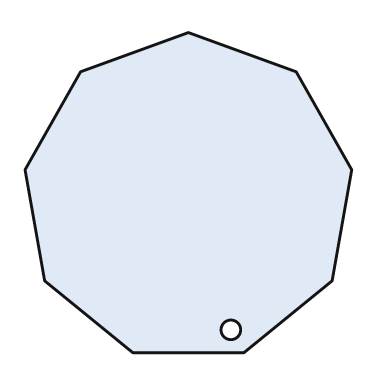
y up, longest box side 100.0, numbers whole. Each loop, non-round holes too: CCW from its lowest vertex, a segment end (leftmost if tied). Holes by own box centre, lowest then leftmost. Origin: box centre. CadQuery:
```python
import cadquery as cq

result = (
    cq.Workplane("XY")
    .moveTo(-17.0, -49.0)
    .lineTo(17.0, -49.0)
    .lineTo(44.0, -27.0)
    .lineTo(50.0, 7.0)
    .lineTo(33.0, 37.0)
    .lineTo(0.0, 49.0)
    .lineTo(-33.0, 37.0)
    .lineTo(-50.0, 7.0)
    .lineTo(-44.0, -27.0)
    .close()
    .moveTo(13.0, -42.0)
    .circle(3.0)
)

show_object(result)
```